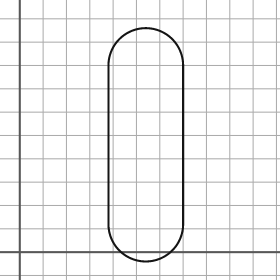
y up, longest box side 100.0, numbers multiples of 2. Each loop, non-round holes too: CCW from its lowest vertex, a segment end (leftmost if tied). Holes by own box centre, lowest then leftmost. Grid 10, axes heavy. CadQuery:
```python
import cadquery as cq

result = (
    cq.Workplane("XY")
    .moveTo(38.0, 12.0)
    .threePointArc((54.0, -4.0), (70.0, 12.0))
    .lineTo(70.0, 80.0)
    .threePointArc((54.0, 96.0), (38.0, 80.0))
    .close()
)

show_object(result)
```